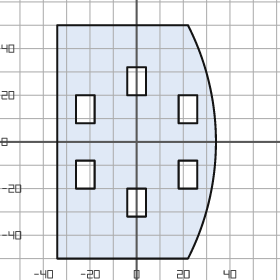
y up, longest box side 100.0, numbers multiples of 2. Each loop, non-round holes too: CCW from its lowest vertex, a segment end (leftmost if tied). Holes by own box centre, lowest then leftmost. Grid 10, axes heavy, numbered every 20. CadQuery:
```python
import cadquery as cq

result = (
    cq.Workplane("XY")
    .moveTo(-34.0, -50.0)
    .lineTo(22.0, -50.0)
    .threePointArc((34.0, 0.0), (22.0, 50.0))
    .lineTo(-34.0, 50.0)
    .close()
    .moveTo(-4.0, -32.0)
    .lineTo(4.0, -32.0)
    .lineTo(4.0, -20.0)
    .lineTo(-4.0, -20.0)
    .close()
    .moveTo(-26.0, -20.0)
    .lineTo(-18.0, -20.0)
    .lineTo(-18.0, -8.0)
    .lineTo(-26.0, -8.0)
    .close()
    .moveTo(18.0, -20.0)
    .lineTo(26.0, -20.0)
    .lineTo(26.0, -8.0)
    .lineTo(18.0, -8.0)
    .close()
    .moveTo(-26.0, 8.0)
    .lineTo(-18.0, 8.0)
    .lineTo(-18.0, 20.0)
    .lineTo(-26.0, 20.0)
    .close()
    .moveTo(18.0, 8.0)
    .lineTo(26.0, 8.0)
    .lineTo(26.0, 20.0)
    .lineTo(18.0, 20.0)
    .close()
    .moveTo(-4.0, 20.0)
    .lineTo(4.0, 20.0)
    .lineTo(4.0, 32.0)
    .lineTo(-4.0, 32.0)
    .close()
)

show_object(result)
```